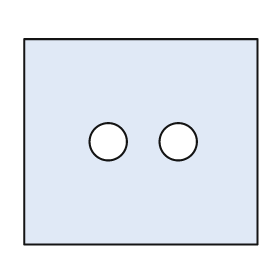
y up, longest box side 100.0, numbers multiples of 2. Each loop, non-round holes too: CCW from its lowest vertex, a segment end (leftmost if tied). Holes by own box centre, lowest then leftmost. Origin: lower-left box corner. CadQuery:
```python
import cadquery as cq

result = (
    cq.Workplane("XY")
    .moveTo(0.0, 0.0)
    .lineTo(100.0, 0.0)
    .lineTo(100.0, 88.0)
    .lineTo(0.0, 88.0)
    .close()
    .moveTo(36.0, 44.0)
    .circle(8.0)
    .moveTo(66.0, 44.0)
    .circle(8.0)
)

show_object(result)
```